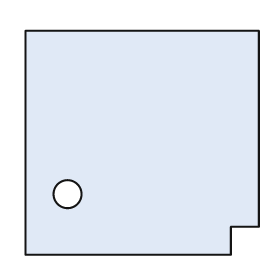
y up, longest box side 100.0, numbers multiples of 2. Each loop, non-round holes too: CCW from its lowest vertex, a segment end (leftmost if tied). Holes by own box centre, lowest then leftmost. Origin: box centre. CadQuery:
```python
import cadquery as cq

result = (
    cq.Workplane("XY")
    .moveTo(-50.0, -48.0)
    .lineTo(38.0, -48.0)
    .lineTo(38.0, -36.0)
    .lineTo(50.0, -36.0)
    .lineTo(50.0, 48.0)
    .lineTo(-50.0, 48.0)
    .close()
    .moveTo(-32.0, -22.0)
    .circle(6.0)
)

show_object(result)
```